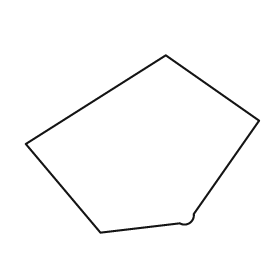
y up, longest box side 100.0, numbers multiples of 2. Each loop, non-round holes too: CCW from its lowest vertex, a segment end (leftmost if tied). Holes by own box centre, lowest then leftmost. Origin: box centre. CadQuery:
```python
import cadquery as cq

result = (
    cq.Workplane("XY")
    .moveTo(-18.0, -38.0)
    .lineTo(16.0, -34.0)
    .threePointArc((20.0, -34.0), (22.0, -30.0))
    .lineTo(50.0, 10.0)
    .lineTo(10.0, 38.0)
    .lineTo(-50.0, 0.0)
    .close()
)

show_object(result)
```